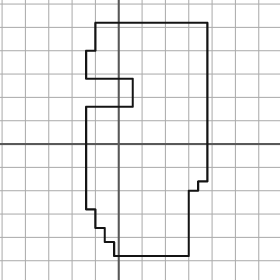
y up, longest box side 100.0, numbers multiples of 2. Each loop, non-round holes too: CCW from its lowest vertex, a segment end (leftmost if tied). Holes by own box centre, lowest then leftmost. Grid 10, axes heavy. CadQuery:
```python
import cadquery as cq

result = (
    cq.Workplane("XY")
    .moveTo(-2.0, -48.0)
    .lineTo(30.0, -48.0)
    .lineTo(30.0, -20.0)
    .lineTo(34.0, -20.0)
    .lineTo(34.0, -16.0)
    .lineTo(38.0, -16.0)
    .lineTo(38.0, 52.0)
    .lineTo(-10.0, 52.0)
    .lineTo(-10.0, 40.0)
    .lineTo(-14.0, 40.0)
    .lineTo(-14.0, 28.0)
    .lineTo(6.0, 28.0)
    .lineTo(6.0, 16.0)
    .lineTo(-14.0, 16.0)
    .lineTo(-14.0, -28.0)
    .lineTo(-10.0, -28.0)
    .lineTo(-10.0, -36.0)
    .lineTo(-6.0, -36.0)
    .lineTo(-6.0, -42.0)
    .lineTo(-2.0, -42.0)
    .close()
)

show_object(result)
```